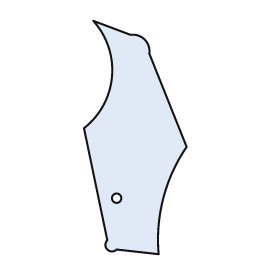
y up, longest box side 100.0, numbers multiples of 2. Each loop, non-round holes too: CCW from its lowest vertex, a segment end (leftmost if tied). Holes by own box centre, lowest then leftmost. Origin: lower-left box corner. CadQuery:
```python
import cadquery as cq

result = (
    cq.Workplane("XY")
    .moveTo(32.0, 0.0)
    .threePointArc((34.0, 24.0), (44.0, 46.0))
    .lineTo(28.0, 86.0)
    .threePointArc((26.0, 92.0), (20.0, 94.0))
    .lineTo(4.0, 100.0)
    .threePointArc((12.0, 76.0), (0.0, 54.0))
    .lineTo(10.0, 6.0)
    .threePointArc((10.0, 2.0), (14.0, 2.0))
    .close()
    .moveTo(14.0, 24.0)
    .circle(2.0)
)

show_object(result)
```